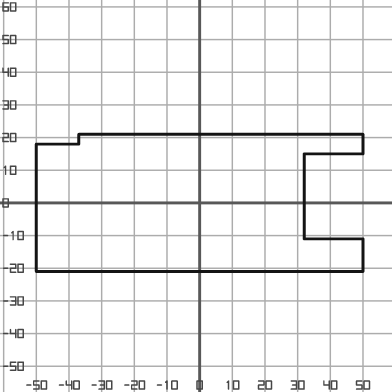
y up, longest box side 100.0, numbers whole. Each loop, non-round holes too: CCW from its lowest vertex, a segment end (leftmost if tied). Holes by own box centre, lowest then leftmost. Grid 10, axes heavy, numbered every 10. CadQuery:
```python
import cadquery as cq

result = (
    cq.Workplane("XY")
    .moveTo(-50.0, -21.0)
    .lineTo(50.0, -21.0)
    .lineTo(50.0, -11.0)
    .lineTo(32.0, -11.0)
    .lineTo(32.0, 15.0)
    .lineTo(50.0, 15.0)
    .lineTo(50.0, 21.0)
    .lineTo(-37.0, 21.0)
    .lineTo(-37.0, 18.0)
    .lineTo(-50.0, 18.0)
    .close()
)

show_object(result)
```